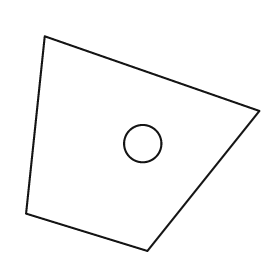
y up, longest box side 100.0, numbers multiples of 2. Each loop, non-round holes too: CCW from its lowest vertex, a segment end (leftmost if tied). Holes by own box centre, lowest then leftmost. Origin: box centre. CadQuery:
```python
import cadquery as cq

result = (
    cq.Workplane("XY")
    .moveTo(2.0, -46.0)
    .lineTo(50.0, 14.0)
    .lineTo(-42.0, 46.0)
    .lineTo(-50.0, -30.0)
    .close()
    .moveTo(0.0, 0.0)
    .circle(8.0)
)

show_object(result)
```